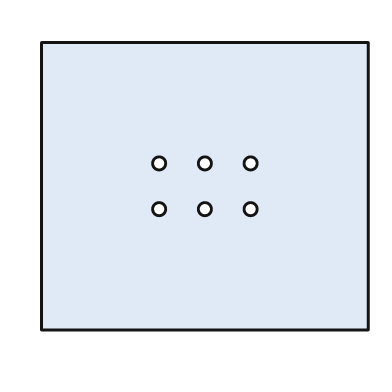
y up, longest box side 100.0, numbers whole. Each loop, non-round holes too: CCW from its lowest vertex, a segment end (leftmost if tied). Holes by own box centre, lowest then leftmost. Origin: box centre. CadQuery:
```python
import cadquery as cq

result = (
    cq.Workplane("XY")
    .moveTo(-50.0, -44.0)
    .lineTo(50.0, -44.0)
    .lineTo(50.0, 44.0)
    .lineTo(-50.0, 44.0)
    .close()
    .moveTo(-14.0, -7.0)
    .circle(2.0)
    .moveTo(0.0, -7.0)
    .circle(2.0)
    .moveTo(14.0, -7.0)
    .circle(2.0)
    .moveTo(-14.0, 7.0)
    .circle(2.0)
    .moveTo(0.0, 7.0)
    .circle(2.0)
    .moveTo(14.0, 7.0)
    .circle(2.0)
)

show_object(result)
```